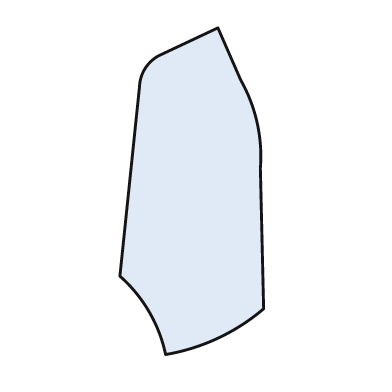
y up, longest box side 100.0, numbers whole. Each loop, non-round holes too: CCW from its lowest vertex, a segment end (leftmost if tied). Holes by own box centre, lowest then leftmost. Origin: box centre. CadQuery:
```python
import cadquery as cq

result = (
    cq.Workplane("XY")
    .moveTo(-8.0, -50.0)
    .threePointArc((8.0, -45.0), (22.0, -36.0))
    .lineTo(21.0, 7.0)
    .threePointArc((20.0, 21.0), (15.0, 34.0))
    .lineTo(8.0, 50.0)
    .lineTo(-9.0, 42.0)
    .threePointArc((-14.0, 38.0), (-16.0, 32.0))
    .lineTo(-22.0, -26.0)
    .threePointArc((-13.0, -37.0), (-8.0, -50.0))
    .close()
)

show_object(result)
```